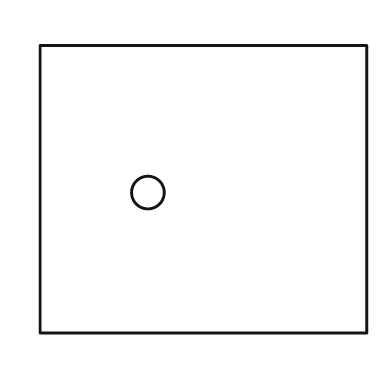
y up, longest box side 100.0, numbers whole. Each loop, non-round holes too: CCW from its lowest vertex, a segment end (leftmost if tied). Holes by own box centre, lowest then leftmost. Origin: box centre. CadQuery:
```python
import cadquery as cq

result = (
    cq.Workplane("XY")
    .moveTo(-50.0, -44.0)
    .lineTo(50.0, -44.0)
    .lineTo(50.0, 44.0)
    .lineTo(-50.0, 44.0)
    .close()
    .moveTo(-17.0, -1.0)
    .circle(5.0)
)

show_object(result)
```